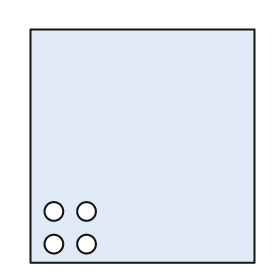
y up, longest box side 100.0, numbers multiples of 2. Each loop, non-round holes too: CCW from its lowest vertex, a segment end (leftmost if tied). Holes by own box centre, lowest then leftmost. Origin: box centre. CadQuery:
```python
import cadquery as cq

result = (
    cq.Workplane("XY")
    .moveTo(-48.0, -50.0)
    .lineTo(48.0, -50.0)
    .lineTo(48.0, 50.0)
    .lineTo(-48.0, 50.0)
    .close()
    .moveTo(-38.0, -42.0)
    .circle(4.0)
    .moveTo(-24.0, -42.0)
    .circle(4.0)
    .moveTo(-38.0, -28.0)
    .circle(4.0)
    .moveTo(-24.0, -28.0)
    .circle(4.0)
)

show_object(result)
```